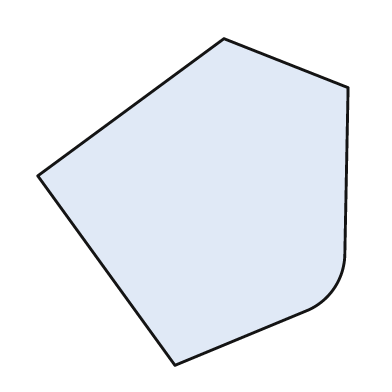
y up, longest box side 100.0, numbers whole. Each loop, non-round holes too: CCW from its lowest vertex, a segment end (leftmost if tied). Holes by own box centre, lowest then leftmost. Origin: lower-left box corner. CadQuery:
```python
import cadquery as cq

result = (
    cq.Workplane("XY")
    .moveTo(42.0, 0.0)
    .lineTo(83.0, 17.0)
    .threePointArc((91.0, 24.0), (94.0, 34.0))
    .lineTo(95.0, 85.0)
    .lineTo(57.0, 100.0)
    .lineTo(0.0, 58.0)
    .close()
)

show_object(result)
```